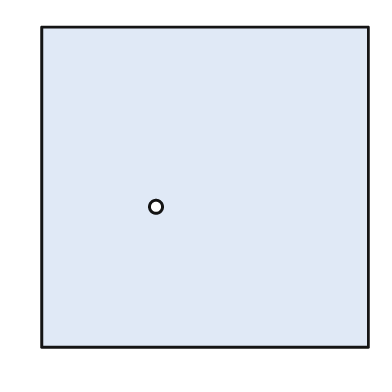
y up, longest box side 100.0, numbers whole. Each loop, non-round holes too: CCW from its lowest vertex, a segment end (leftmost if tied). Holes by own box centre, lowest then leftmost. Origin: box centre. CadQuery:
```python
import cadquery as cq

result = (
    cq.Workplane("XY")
    .moveTo(-50.0, -49.0)
    .lineTo(50.0, -49.0)
    .lineTo(50.0, 49.0)
    .lineTo(-50.0, 49.0)
    .close()
    .moveTo(-15.0, -6.0)
    .circle(2.0)
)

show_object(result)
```